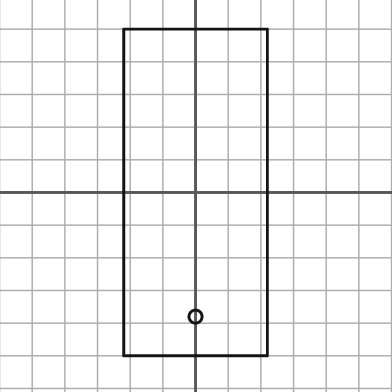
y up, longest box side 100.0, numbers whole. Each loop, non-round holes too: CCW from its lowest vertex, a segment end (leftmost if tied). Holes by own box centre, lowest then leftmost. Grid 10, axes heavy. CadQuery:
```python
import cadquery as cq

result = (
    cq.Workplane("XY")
    .moveTo(-22.0, -50.0)
    .lineTo(22.0, -50.0)
    .lineTo(22.0, 50.0)
    .lineTo(-22.0, 50.0)
    .close()
    .moveTo(0.0, -38.0)
    .circle(2.0)
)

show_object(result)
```